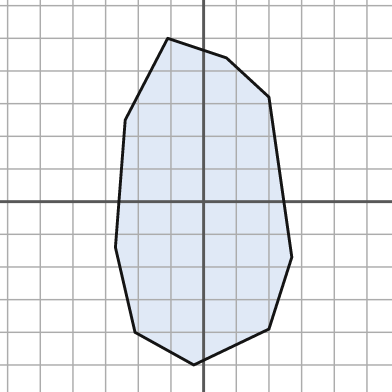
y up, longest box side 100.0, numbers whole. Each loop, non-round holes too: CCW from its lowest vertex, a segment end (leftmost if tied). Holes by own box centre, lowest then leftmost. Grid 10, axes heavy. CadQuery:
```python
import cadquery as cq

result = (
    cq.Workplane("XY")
    .moveTo(-3.0, -50.0)
    .lineTo(20.0, -39.0)
    .lineTo(27.0, -17.0)
    .lineTo(20.0, 32.0)
    .lineTo(7.0, 44.0)
    .lineTo(-11.0, 50.0)
    .lineTo(-24.0, 25.0)
    .lineTo(-27.0, -14.0)
    .lineTo(-21.0, -40.0)
    .close()
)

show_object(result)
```